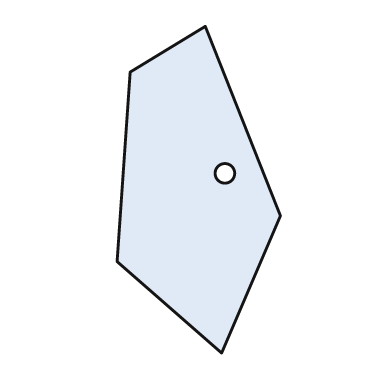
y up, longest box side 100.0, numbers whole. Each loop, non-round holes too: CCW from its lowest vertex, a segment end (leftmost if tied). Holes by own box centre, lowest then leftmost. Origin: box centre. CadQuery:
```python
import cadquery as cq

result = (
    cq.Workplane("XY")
    .moveTo(7.0, -50.0)
    .lineTo(25.0, -8.0)
    .lineTo(2.0, 50.0)
    .lineTo(-21.0, 36.0)
    .lineTo(-25.0, -22.0)
    .close()
    .moveTo(8.0, 5.0)
    .circle(3.0)
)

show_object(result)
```